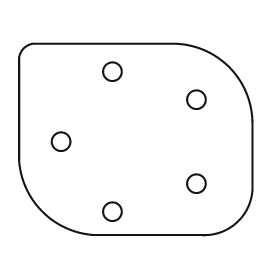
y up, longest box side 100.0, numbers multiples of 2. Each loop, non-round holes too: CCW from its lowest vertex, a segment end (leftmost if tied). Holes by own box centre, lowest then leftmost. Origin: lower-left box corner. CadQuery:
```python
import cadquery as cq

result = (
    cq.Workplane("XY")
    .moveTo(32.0, 0.0)
    .lineTo(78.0, 0.0)
    .threePointArc((94.0, 6.0), (100.0, 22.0))
    .lineTo(100.0, 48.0)
    .threePointArc((90.0, 72.0), (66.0, 82.0))
    .lineTo(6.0, 82.0)
    .threePointArc((2.0, 80.0), (0.0, 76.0))
    .lineTo(0.0, 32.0)
    .threePointArc((10.0, 10.0), (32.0, 0.0))
    .close()
    .moveTo(40.0, 10.0)
    .circle(4.0)
    .moveTo(76.0, 22.0)
    .circle(4.0)
    .moveTo(18.0, 40.0)
    .circle(4.0)
    .moveTo(76.0, 58.0)
    .circle(4.0)
    .moveTo(40.0, 70.0)
    .circle(4.0)
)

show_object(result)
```